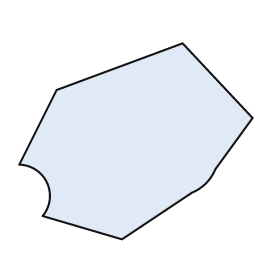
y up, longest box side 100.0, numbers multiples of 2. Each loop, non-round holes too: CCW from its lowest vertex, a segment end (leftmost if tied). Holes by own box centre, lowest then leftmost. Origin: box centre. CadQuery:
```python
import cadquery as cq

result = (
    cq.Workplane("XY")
    .moveTo(-6.0, -42.0)
    .lineTo(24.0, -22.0)
    .threePointArc((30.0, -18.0), (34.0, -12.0))
    .lineTo(50.0, 10.0)
    .lineTo(20.0, 42.0)
    .lineTo(-34.0, 22.0)
    .lineTo(-50.0, -10.0)
    .threePointArc((-38.0, -18.0), (-40.0, -32.0))
    .close()
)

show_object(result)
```